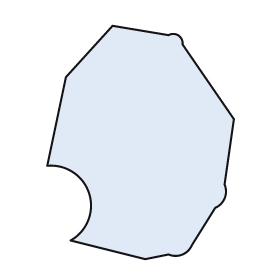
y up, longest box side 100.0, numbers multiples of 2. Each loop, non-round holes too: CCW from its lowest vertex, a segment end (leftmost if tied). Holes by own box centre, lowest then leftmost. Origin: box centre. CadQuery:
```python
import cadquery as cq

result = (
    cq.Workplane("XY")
    .moveTo(2.0, -50.0)
    .lineTo(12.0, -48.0)
    .threePointArc((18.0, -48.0), (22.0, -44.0))
    .lineTo(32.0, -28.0)
    .threePointArc((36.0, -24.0), (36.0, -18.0))
    .lineTo(40.0, 10.0)
    .lineTo(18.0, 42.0)
    .threePointArc((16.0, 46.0), (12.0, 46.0))
    .lineTo(-12.0, 50.0)
    .lineTo(-32.0, 28.0)
    .lineTo(-40.0, -10.0)
    .threePointArc((-22.0, -22.0), (-30.0, -42.0))
    .close()
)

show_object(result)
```